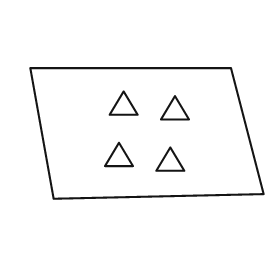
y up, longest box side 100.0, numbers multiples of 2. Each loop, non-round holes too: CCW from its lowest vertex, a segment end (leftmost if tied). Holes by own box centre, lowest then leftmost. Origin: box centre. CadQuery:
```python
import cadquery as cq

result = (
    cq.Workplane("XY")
    .moveTo(-40.0, -28.0)
    .lineTo(50.0, -26.0)
    .lineTo(36.0, 28.0)
    .lineTo(-50.0, 28.0)
    .close()
    .moveTo(4.0, -16.0)
    .lineTo(16.0, -16.0)
    .lineTo(10.0, -6.0)
    .close()
    .moveTo(-18.0, -14.0)
    .lineTo(-6.0, -14.0)
    .lineTo(-12.0, -4.0)
    .close()
    .moveTo(6.0, 6.0)
    .lineTo(18.0, 6.0)
    .lineTo(12.0, 16.0)
    .close()
    .moveTo(-16.0, 8.0)
    .lineTo(-4.0, 8.0)
    .lineTo(-10.0, 18.0)
    .close()
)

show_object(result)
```